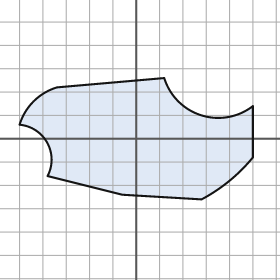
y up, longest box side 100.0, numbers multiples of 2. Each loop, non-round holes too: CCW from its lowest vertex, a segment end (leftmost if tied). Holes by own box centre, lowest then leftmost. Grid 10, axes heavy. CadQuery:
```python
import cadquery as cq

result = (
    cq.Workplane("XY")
    .moveTo(28.0, -26.0)
    .threePointArc((40.0, -18.0), (50.0, -8.0))
    .lineTo(50.0, 14.0)
    .threePointArc((28.0, 10.0), (12.0, 26.0))
    .lineTo(-34.0, 22.0)
    .threePointArc((-44.0, 16.0), (-50.0, 6.0))
    .threePointArc((-38.0, -2.0), (-38.0, -16.0))
    .lineTo(-6.0, -24.0)
    .close()
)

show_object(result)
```